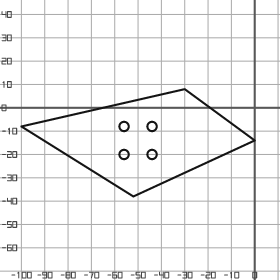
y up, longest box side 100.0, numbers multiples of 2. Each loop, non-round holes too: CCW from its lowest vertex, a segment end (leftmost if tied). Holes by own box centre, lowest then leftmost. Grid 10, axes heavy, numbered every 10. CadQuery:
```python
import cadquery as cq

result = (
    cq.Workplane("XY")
    .moveTo(-52.0, -38.0)
    .lineTo(0.0, -14.0)
    .lineTo(-30.0, 8.0)
    .lineTo(-100.0, -8.0)
    .close()
    .moveTo(-56.0, -20.0)
    .circle(2.0)
    .moveTo(-44.0, -20.0)
    .circle(2.0)
    .moveTo(-56.0, -8.0)
    .circle(2.0)
    .moveTo(-44.0, -8.0)
    .circle(2.0)
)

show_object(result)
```